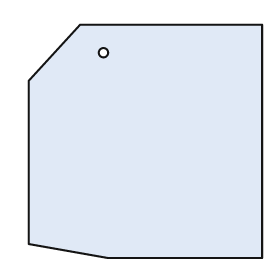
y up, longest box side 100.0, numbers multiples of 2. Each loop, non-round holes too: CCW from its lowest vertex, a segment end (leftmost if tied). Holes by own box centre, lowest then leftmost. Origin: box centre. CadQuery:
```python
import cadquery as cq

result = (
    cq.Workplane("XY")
    .moveTo(-16.0, -50.0)
    .lineTo(50.0, -50.0)
    .lineTo(50.0, 50.0)
    .lineTo(-28.0, 50.0)
    .lineTo(-50.0, 26.0)
    .lineTo(-50.0, -44.0)
    .close()
    .moveTo(-18.0, 38.0)
    .circle(2.0)
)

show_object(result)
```